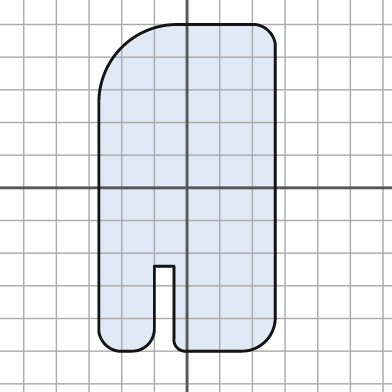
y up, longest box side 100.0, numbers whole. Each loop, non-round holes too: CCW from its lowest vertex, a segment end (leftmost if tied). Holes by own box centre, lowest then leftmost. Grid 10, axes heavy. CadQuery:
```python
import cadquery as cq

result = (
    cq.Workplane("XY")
    .moveTo(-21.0, -50.0)
    .lineTo(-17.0, -50.0)
    .threePointArc((-12.0, -48.0), (-10.0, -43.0))
    .lineTo(-10.0, -24.0)
    .lineTo(-4.0, -24.0)
    .lineTo(-4.0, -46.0)
    .threePointArc((-3.0, -49.0), (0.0, -50.0))
    .lineTo(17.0, -50.0)
    .threePointArc((24.0, -47.0), (27.0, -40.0))
    .lineTo(27.0, 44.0)
    .threePointArc((25.0, 48.0), (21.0, 50.0))
    .lineTo(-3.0, 50.0)
    .threePointArc((-20.0, 43.0), (-27.0, 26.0))
    .lineTo(-27.0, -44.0)
    .threePointArc((-25.0, -48.0), (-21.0, -50.0))
    .close()
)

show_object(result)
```